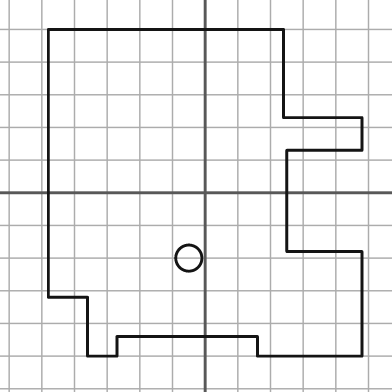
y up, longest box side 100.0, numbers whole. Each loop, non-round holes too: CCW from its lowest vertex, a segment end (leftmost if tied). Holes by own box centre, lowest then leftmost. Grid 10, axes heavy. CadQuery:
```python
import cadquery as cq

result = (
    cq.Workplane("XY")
    .moveTo(-36.0, -50.0)
    .lineTo(-27.0, -50.0)
    .lineTo(-27.0, -44.0)
    .lineTo(16.0, -44.0)
    .lineTo(16.0, -50.0)
    .lineTo(48.0, -50.0)
    .lineTo(48.0, -18.0)
    .lineTo(25.0, -18.0)
    .lineTo(25.0, 13.0)
    .lineTo(48.0, 13.0)
    .lineTo(48.0, 23.0)
    .lineTo(24.0, 23.0)
    .lineTo(24.0, 50.0)
    .lineTo(-48.0, 50.0)
    .lineTo(-48.0, -32.0)
    .lineTo(-36.0, -32.0)
    .close()
    .moveTo(-5.0, -20.0)
    .circle(4.0)
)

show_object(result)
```